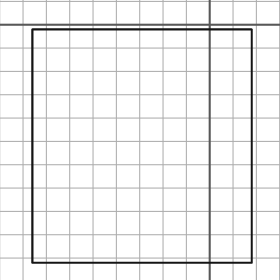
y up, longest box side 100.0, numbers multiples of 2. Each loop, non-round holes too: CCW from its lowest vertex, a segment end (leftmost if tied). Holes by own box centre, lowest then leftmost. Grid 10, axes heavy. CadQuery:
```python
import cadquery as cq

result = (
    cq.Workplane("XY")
    .moveTo(-76.0, -102.0)
    .lineTo(18.0, -102.0)
    .lineTo(18.0, -2.0)
    .lineTo(-76.0, -2.0)
    .close()
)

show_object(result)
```